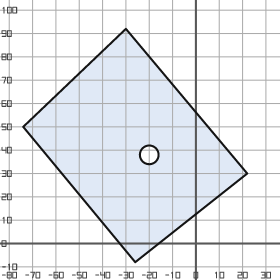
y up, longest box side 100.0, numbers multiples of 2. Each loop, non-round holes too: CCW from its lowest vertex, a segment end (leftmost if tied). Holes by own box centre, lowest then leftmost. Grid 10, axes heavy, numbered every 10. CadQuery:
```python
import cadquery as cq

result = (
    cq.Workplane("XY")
    .moveTo(-26.0, -8.0)
    .lineTo(22.0, 30.0)
    .lineTo(-30.0, 92.0)
    .lineTo(-74.0, 50.0)
    .close()
    .moveTo(-20.0, 38.0)
    .circle(4.0)
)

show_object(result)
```